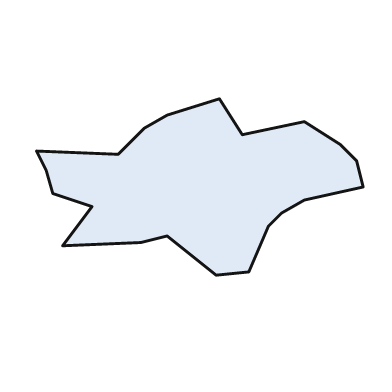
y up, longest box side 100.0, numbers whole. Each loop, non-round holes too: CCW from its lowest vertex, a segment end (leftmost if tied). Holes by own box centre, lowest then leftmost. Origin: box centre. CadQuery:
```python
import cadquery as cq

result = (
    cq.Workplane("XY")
    .moveTo(5.0, -27.0)
    .lineTo(15.0, -26.0)
    .lineTo(21.0, -12.0)
    .lineTo(25.0, -8.0)
    .lineTo(32.0, -4.0)
    .lineTo(50.0, 0.0)
    .lineTo(48.0, 8.0)
    .lineTo(43.0, 13.0)
    .lineTo(32.0, 20.0)
    .lineTo(13.0, 16.0)
    .lineTo(6.0, 27.0)
    .lineTo(-10.0, 22.0)
    .lineTo(-17.0, 18.0)
    .lineTo(-25.0, 10.0)
    .lineTo(-50.0, 11.0)
    .lineTo(-47.0, 5.0)
    .lineTo(-45.0, -2.0)
    .lineTo(-33.0, -6.0)
    .lineTo(-42.0, -18.0)
    .lineTo(-18.0, -17.0)
    .lineTo(-10.0, -15.0)
    .close()
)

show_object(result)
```